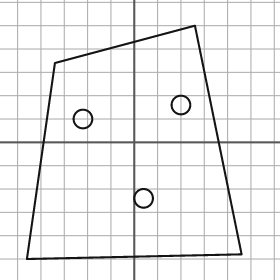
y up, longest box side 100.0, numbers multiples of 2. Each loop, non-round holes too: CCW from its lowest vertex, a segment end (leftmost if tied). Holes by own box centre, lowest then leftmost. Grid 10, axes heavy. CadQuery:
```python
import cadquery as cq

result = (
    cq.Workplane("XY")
    .moveTo(-46.0, -50.0)
    .lineTo(46.0, -48.0)
    .lineTo(26.0, 50.0)
    .lineTo(-34.0, 34.0)
    .close()
    .moveTo(4.0, -24.0)
    .circle(4.0)
    .moveTo(-22.0, 10.0)
    .circle(4.0)
    .moveTo(20.0, 16.0)
    .circle(4.0)
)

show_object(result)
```